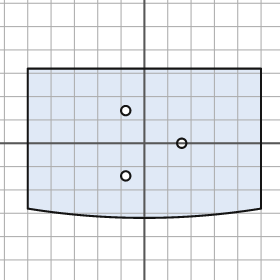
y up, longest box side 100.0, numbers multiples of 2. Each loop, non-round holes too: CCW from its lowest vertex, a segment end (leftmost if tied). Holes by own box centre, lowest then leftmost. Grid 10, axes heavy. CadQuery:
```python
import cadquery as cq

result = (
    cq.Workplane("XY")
    .moveTo(-50.0, -28.0)
    .threePointArc((0.0, -32.0), (50.0, -28.0))
    .lineTo(50.0, 32.0)
    .lineTo(-50.0, 32.0)
    .close()
    .moveTo(-8.0, -14.0)
    .circle(2.0)
    .moveTo(16.0, 0.0)
    .circle(2.0)
    .moveTo(-8.0, 14.0)
    .circle(2.0)
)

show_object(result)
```